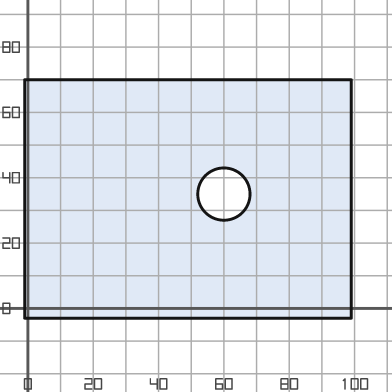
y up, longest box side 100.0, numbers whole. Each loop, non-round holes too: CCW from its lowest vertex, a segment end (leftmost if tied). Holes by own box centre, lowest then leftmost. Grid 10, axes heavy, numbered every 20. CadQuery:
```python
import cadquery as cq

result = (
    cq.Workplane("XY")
    .moveTo(-1.0, -3.0)
    .lineTo(99.0, -3.0)
    .lineTo(99.0, 70.0)
    .lineTo(-1.0, 70.0)
    .close()
    .moveTo(60.0, 35.0)
    .circle(8.0)
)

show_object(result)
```